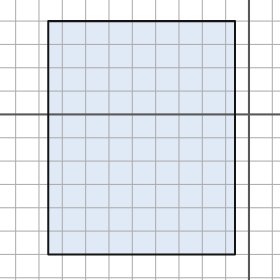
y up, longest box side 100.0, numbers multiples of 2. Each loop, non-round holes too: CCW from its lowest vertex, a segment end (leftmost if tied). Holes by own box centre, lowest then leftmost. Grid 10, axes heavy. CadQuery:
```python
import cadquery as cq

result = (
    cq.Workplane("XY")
    .moveTo(-86.0, -60.0)
    .lineTo(-6.0, -60.0)
    .lineTo(-6.0, 40.0)
    .lineTo(-86.0, 40.0)
    .close()
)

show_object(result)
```